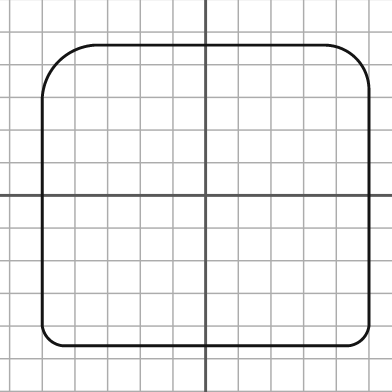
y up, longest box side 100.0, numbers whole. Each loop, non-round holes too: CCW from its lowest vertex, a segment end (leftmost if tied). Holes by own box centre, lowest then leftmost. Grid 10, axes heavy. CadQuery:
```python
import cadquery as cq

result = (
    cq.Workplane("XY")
    .moveTo(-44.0, -46.0)
    .lineTo(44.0, -46.0)
    .threePointArc((48.0, -44.0), (50.0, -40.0))
    .lineTo(50.0, 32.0)
    .threePointArc((46.0, 42.0), (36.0, 46.0))
    .lineTo(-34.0, 46.0)
    .threePointArc((-45.0, 41.0), (-50.0, 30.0))
    .lineTo(-50.0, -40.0)
    .threePointArc((-48.0, -44.0), (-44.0, -46.0))
    .close()
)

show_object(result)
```